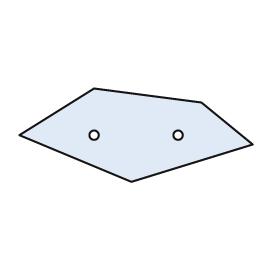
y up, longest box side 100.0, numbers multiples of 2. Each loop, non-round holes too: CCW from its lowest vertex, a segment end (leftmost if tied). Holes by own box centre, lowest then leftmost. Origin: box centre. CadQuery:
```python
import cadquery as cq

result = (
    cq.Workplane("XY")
    .moveTo(-2.0, -20.0)
    .lineTo(50.0, -4.0)
    .lineTo(28.0, 14.0)
    .lineTo(-18.0, 20.0)
    .lineTo(-50.0, 0.0)
    .close()
    .moveTo(-18.0, 0.0)
    .circle(2.0)
    .moveTo(18.0, 0.0)
    .circle(2.0)
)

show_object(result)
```